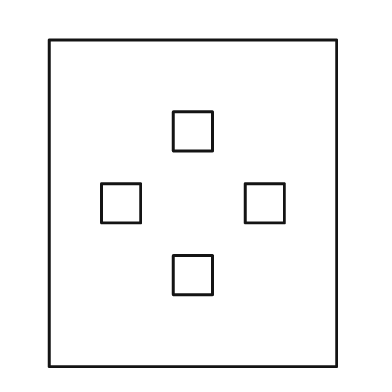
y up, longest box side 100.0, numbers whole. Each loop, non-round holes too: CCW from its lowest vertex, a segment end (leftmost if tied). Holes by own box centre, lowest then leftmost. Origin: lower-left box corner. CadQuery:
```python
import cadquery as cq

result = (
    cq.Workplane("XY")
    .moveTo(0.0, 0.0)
    .lineTo(88.0, 0.0)
    .lineTo(88.0, 100.0)
    .lineTo(0.0, 100.0)
    .close()
    .moveTo(38.0, 22.0)
    .lineTo(50.0, 22.0)
    .lineTo(50.0, 34.0)
    .lineTo(38.0, 34.0)
    .close()
    .moveTo(16.0, 44.0)
    .lineTo(28.0, 44.0)
    .lineTo(28.0, 56.0)
    .lineTo(16.0, 56.0)
    .close()
    .moveTo(60.0, 44.0)
    .lineTo(72.0, 44.0)
    .lineTo(72.0, 56.0)
    .lineTo(60.0, 56.0)
    .close()
    .moveTo(38.0, 66.0)
    .lineTo(50.0, 66.0)
    .lineTo(50.0, 78.0)
    .lineTo(38.0, 78.0)
    .close()
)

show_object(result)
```